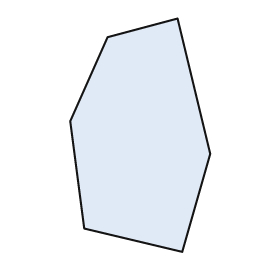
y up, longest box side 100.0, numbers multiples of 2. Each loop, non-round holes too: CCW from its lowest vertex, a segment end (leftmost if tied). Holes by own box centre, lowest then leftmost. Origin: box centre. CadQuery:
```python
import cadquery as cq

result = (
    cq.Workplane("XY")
    .moveTo(18.0, -50.0)
    .lineTo(30.0, -8.0)
    .lineTo(16.0, 50.0)
    .lineTo(-14.0, 42.0)
    .lineTo(-30.0, 6.0)
    .lineTo(-24.0, -40.0)
    .close()
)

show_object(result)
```